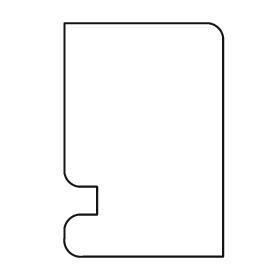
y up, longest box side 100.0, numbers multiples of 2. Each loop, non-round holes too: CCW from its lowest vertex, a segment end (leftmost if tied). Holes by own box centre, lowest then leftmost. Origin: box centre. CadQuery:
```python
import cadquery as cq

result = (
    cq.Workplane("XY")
    .moveTo(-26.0, -50.0)
    .lineTo(34.0, -50.0)
    .lineTo(34.0, 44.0)
    .threePointArc((32.0, 48.0), (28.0, 50.0))
    .lineTo(-34.0, 50.0)
    .lineTo(-34.0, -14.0)
    .threePointArc((-32.0, -18.0), (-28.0, -20.0))
    .lineTo(-20.0, -20.0)
    .lineTo(-20.0, -32.0)
    .lineTo(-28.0, -32.0)
    .threePointArc((-32.0, -34.0), (-34.0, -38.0))
    .lineTo(-34.0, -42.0)
    .threePointArc((-32.0, -48.0), (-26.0, -50.0))
    .close()
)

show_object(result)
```